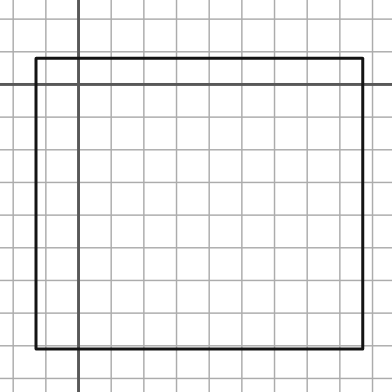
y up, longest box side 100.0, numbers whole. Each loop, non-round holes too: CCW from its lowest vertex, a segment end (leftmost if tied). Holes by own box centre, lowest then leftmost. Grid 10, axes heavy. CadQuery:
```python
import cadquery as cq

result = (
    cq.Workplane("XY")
    .moveTo(-13.0, -81.0)
    .lineTo(87.0, -81.0)
    .lineTo(87.0, 8.0)
    .lineTo(-13.0, 8.0)
    .close()
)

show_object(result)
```